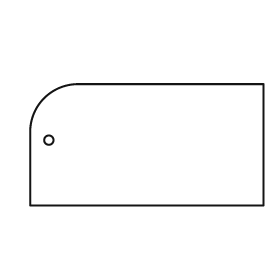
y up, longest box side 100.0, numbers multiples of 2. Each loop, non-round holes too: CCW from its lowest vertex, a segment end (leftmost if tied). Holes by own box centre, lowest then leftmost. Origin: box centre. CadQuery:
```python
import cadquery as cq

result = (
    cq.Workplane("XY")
    .moveTo(-50.0, -26.0)
    .lineTo(50.0, -26.0)
    .lineTo(50.0, 26.0)
    .lineTo(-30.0, 26.0)
    .threePointArc((-44.0, 20.0), (-50.0, 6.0))
    .close()
    .moveTo(-42.0, 2.0)
    .circle(2.0)
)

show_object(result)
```